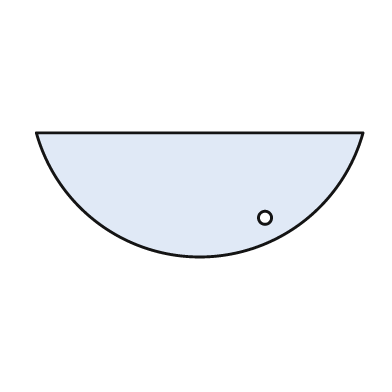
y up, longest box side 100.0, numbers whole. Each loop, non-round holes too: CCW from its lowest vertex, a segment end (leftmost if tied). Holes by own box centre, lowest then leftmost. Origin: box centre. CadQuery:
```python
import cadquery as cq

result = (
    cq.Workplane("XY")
    .moveTo(-50.0, 19.0)
    .threePointArc((0.0, -19.0), (50.0, 19.0))
    .close()
    .moveTo(20.0, -7.0)
    .circle(2.0)
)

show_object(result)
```